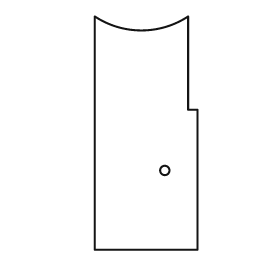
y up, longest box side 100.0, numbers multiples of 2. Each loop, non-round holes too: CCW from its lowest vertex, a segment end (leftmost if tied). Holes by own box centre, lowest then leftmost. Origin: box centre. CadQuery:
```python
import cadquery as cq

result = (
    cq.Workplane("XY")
    .moveTo(-22.0, -50.0)
    .lineTo(22.0, -50.0)
    .lineTo(22.0, 10.0)
    .lineTo(18.0, 10.0)
    .lineTo(18.0, 50.0)
    .threePointArc((-2.0, 44.0), (-22.0, 50.0))
    .close()
    .moveTo(8.0, -16.0)
    .circle(2.0)
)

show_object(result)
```